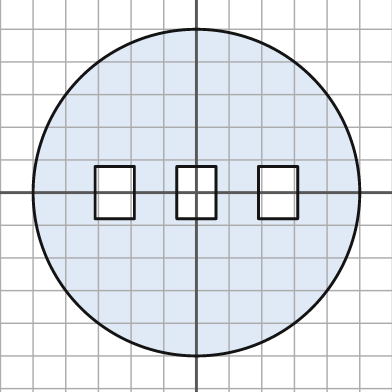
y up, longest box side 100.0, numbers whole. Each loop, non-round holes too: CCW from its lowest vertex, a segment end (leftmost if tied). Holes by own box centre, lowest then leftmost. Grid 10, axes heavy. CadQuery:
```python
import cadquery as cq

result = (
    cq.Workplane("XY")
    .moveTo(0.0, 0.0)
    .circle(50.0)
    .moveTo(-31.0, -8.0)
    .lineTo(-19.0, -8.0)
    .lineTo(-19.0, 8.0)
    .lineTo(-31.0, 8.0)
    .close()
    .moveTo(-6.0, -8.0)
    .lineTo(6.0, -8.0)
    .lineTo(6.0, 8.0)
    .lineTo(-6.0, 8.0)
    .close()
    .moveTo(19.0, -8.0)
    .lineTo(31.0, -8.0)
    .lineTo(31.0, 8.0)
    .lineTo(19.0, 8.0)
    .close()
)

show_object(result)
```